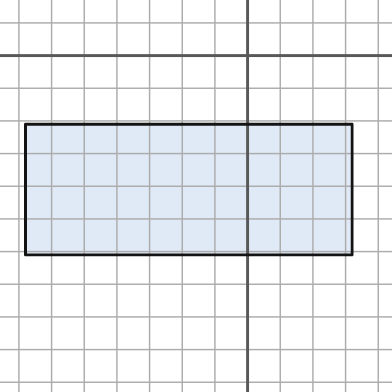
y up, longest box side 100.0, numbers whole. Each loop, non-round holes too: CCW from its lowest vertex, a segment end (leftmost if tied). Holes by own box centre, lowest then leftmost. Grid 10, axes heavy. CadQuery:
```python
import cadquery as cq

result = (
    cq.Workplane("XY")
    .moveTo(-68.0, -61.0)
    .lineTo(32.0, -61.0)
    .lineTo(32.0, -21.0)
    .lineTo(-68.0, -21.0)
    .close()
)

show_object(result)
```